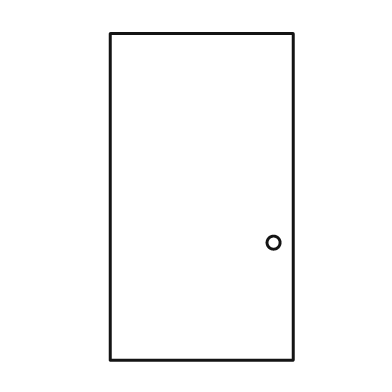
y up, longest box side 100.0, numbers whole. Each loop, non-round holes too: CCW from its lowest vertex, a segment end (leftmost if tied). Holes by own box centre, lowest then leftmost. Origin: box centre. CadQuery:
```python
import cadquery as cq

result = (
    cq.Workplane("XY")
    .moveTo(-28.0, -50.0)
    .lineTo(28.0, -50.0)
    .lineTo(28.0, 50.0)
    .lineTo(-28.0, 50.0)
    .close()
    .moveTo(22.0, -14.0)
    .circle(2.0)
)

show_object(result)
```